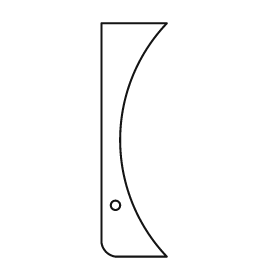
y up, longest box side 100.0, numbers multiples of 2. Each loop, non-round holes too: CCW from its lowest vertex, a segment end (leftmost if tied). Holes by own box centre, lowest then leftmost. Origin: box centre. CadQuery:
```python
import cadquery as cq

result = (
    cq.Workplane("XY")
    .moveTo(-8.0, -50.0)
    .lineTo(14.0, -50.0)
    .threePointArc((-6.0, 0.0), (14.0, 50.0))
    .lineTo(-14.0, 50.0)
    .lineTo(-14.0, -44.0)
    .threePointArc((-12.0, -48.0), (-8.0, -50.0))
    .close()
    .moveTo(-8.0, -28.0)
    .circle(2.0)
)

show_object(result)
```